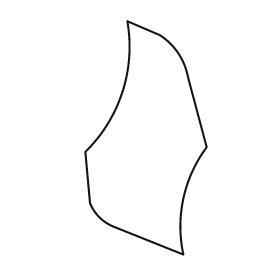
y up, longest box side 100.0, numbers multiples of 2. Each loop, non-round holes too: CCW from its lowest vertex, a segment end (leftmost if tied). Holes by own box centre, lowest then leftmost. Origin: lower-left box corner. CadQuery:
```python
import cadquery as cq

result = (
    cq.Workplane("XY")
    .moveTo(42.0, 0.0)
    .threePointArc((42.0, 24.0), (52.0, 46.0))
    .lineTo(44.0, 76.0)
    .threePointArc((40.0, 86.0), (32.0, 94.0))
    .lineTo(18.0, 100.0)
    .threePointArc((16.0, 70.0), (0.0, 44.0))
    .lineTo(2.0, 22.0)
    .threePointArc((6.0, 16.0), (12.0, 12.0))
    .close()
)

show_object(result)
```